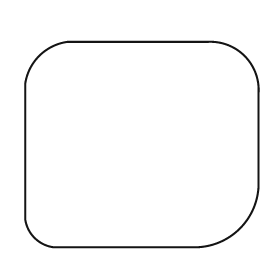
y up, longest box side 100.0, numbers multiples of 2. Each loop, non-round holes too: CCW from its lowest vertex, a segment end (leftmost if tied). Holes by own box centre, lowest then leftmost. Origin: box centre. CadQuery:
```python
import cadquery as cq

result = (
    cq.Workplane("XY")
    .moveTo(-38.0, -44.0)
    .lineTo(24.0, -44.0)
    .threePointArc((42.0, -36.0), (50.0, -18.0))
    .lineTo(50.0, 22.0)
    .threePointArc((44.0, 38.0), (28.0, 44.0))
    .lineTo(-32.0, 44.0)
    .threePointArc((-44.0, 38.0), (-50.0, 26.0))
    .lineTo(-50.0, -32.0)
    .threePointArc((-46.0, -40.0), (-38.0, -44.0))
    .close()
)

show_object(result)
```